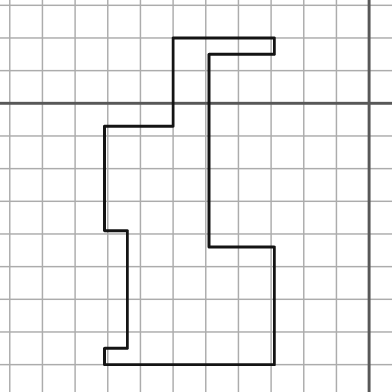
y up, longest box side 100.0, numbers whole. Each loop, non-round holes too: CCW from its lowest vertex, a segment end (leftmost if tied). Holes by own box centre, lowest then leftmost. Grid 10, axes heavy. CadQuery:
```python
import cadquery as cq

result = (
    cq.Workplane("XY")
    .moveTo(-81.0, -80.0)
    .lineTo(-29.0, -80.0)
    .lineTo(-29.0, -44.0)
    .lineTo(-49.0, -44.0)
    .lineTo(-49.0, 15.0)
    .lineTo(-29.0, 15.0)
    .lineTo(-29.0, 20.0)
    .lineTo(-60.0, 20.0)
    .lineTo(-60.0, -7.0)
    .lineTo(-81.0, -7.0)
    .lineTo(-81.0, -39.0)
    .lineTo(-74.0, -39.0)
    .lineTo(-74.0, -75.0)
    .lineTo(-81.0, -75.0)
    .close()
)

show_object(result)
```